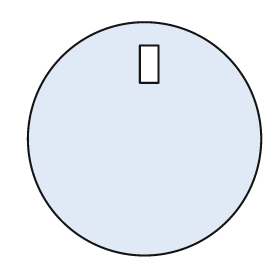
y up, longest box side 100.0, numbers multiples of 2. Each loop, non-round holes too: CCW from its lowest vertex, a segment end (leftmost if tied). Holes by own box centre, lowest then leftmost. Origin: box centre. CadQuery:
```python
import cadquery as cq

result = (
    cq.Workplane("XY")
    .moveTo(0.0, 0.0)
    .circle(50.0)
    .moveTo(-2.0, 24.0)
    .lineTo(6.0, 24.0)
    .lineTo(6.0, 40.0)
    .lineTo(-2.0, 40.0)
    .close()
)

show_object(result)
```